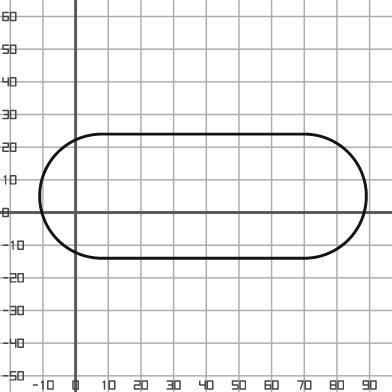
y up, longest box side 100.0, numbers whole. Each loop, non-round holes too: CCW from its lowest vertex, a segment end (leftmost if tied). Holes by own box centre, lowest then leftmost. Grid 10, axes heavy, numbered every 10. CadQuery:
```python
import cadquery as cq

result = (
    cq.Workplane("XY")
    .moveTo(8.0, -14.0)
    .lineTo(70.0, -14.0)
    .threePointArc((89.0, 5.0), (70.0, 24.0))
    .lineTo(8.0, 24.0)
    .threePointArc((-11.0, 5.0), (8.0, -14.0))
    .close()
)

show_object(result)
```